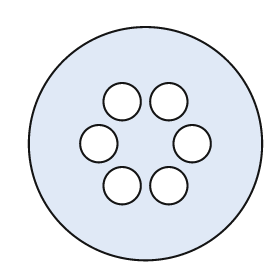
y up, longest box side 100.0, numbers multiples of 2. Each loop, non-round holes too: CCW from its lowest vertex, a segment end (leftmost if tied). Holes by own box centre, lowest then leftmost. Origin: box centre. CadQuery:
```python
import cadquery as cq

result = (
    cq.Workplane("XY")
    .moveTo(0.0, 0.0)
    .circle(50.0)
    .moveTo(-10.0, -18.0)
    .circle(8.0)
    .moveTo(10.0, -18.0)
    .circle(8.0)
    .moveTo(-20.0, 0.0)
    .circle(8.0)
    .moveTo(20.0, 0.0)
    .circle(8.0)
    .moveTo(-10.0, 18.0)
    .circle(8.0)
    .moveTo(10.0, 18.0)
    .circle(8.0)
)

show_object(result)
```